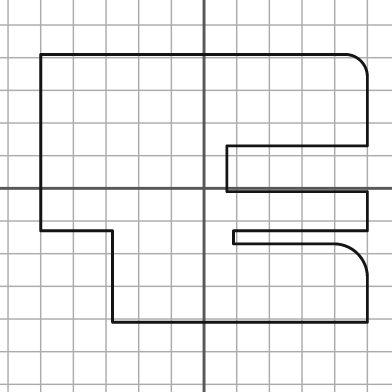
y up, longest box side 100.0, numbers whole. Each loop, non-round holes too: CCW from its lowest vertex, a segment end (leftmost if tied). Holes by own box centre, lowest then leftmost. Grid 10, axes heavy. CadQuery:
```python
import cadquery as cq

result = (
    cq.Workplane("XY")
    .moveTo(-28.0, -41.0)
    .lineTo(50.0, -41.0)
    .lineTo(50.0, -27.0)
    .threePointArc((47.0, -20.0), (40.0, -17.0))
    .lineTo(9.0, -17.0)
    .lineTo(9.0, -13.0)
    .lineTo(50.0, -13.0)
    .lineTo(50.0, -1.0)
    .lineTo(7.0, -1.0)
    .lineTo(7.0, 13.0)
    .lineTo(50.0, 13.0)
    .lineTo(50.0, 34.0)
    .threePointArc((48.0, 39.0), (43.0, 41.0))
    .lineTo(-50.0, 41.0)
    .lineTo(-50.0, -13.0)
    .lineTo(-28.0, -13.0)
    .close()
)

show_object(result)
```